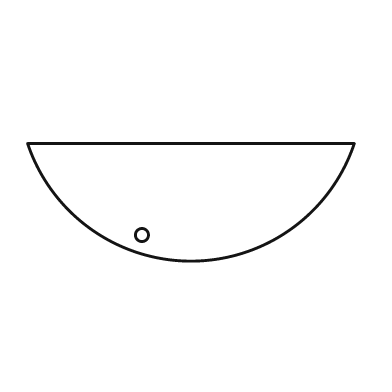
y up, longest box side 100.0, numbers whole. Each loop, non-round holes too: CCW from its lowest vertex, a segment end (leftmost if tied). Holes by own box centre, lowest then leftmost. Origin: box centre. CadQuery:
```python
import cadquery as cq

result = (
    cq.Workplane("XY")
    .moveTo(-50.0, 18.0)
    .threePointArc((0.0, -18.0), (50.0, 18.0))
    .close()
    .moveTo(-15.0, -10.0)
    .circle(2.0)
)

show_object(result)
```